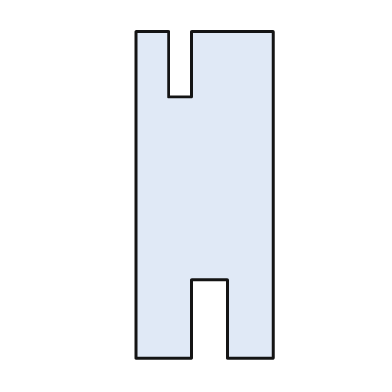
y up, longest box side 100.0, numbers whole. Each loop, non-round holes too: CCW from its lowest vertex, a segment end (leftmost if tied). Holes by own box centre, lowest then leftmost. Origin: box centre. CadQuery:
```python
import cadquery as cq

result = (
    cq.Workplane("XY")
    .moveTo(-21.0, -50.0)
    .lineTo(-4.0, -50.0)
    .lineTo(-4.0, -26.0)
    .lineTo(7.0, -26.0)
    .lineTo(7.0, -50.0)
    .lineTo(21.0, -50.0)
    .lineTo(21.0, 50.0)
    .lineTo(-4.0, 50.0)
    .lineTo(-4.0, 30.0)
    .lineTo(-11.0, 30.0)
    .lineTo(-11.0, 50.0)
    .lineTo(-21.0, 50.0)
    .close()
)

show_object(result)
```